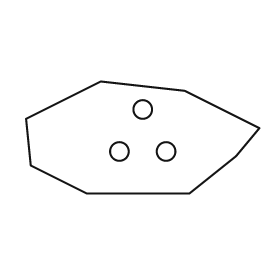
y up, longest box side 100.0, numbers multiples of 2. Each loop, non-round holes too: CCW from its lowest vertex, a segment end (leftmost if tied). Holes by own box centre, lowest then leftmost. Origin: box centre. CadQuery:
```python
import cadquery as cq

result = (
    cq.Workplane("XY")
    .moveTo(-24.0, -24.0)
    .lineTo(20.0, -24.0)
    .lineTo(40.0, -8.0)
    .lineTo(50.0, 4.0)
    .lineTo(18.0, 20.0)
    .lineTo(-18.0, 24.0)
    .lineTo(-50.0, 8.0)
    .lineTo(-48.0, -12.0)
    .close()
    .moveTo(-10.0, -6.0)
    .circle(4.0)
    .moveTo(10.0, -6.0)
    .circle(4.0)
    .moveTo(0.0, 12.0)
    .circle(4.0)
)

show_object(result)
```